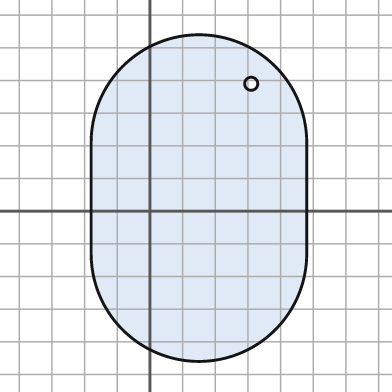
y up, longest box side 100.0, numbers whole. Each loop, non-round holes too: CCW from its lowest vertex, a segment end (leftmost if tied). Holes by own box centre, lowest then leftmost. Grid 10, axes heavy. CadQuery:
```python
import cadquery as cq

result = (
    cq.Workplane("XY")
    .moveTo(-18.0, -13.0)
    .threePointArc((15.0, -46.0), (48.0, -13.0))
    .lineTo(48.0, 21.0)
    .threePointArc((15.0, 54.0), (-18.0, 21.0))
    .close()
    .moveTo(31.0, 39.0)
    .circle(2.0)
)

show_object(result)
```